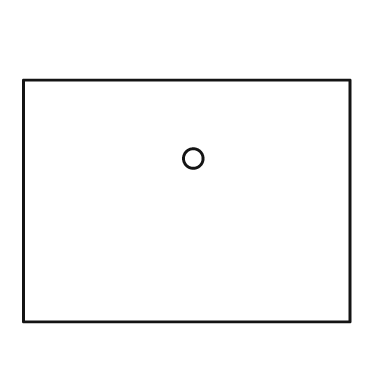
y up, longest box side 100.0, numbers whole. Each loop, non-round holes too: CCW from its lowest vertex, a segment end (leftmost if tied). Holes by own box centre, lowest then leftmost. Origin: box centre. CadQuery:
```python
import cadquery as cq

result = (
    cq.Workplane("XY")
    .moveTo(-50.0, -37.0)
    .lineTo(50.0, -37.0)
    .lineTo(50.0, 37.0)
    .lineTo(-50.0, 37.0)
    .close()
    .moveTo(2.0, 13.0)
    .circle(3.0)
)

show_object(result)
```